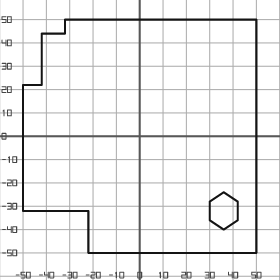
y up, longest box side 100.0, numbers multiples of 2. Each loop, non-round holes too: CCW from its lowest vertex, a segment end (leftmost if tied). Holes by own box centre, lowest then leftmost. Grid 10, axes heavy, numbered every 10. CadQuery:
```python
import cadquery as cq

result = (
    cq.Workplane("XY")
    .moveTo(-22.0, -50.0)
    .lineTo(50.0, -50.0)
    .lineTo(50.0, 50.0)
    .lineTo(-32.0, 50.0)
    .lineTo(-32.0, 44.0)
    .lineTo(-42.0, 44.0)
    .lineTo(-42.0, 22.0)
    .lineTo(-50.0, 22.0)
    .lineTo(-50.0, -32.0)
    .lineTo(-22.0, -32.0)
    .close()
    .moveTo(36.0, -40.0)
    .lineTo(42.0, -36.0)
    .lineTo(42.0, -28.0)
    .lineTo(36.0, -24.0)
    .lineTo(30.0, -28.0)
    .lineTo(30.0, -36.0)
    .close()
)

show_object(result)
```